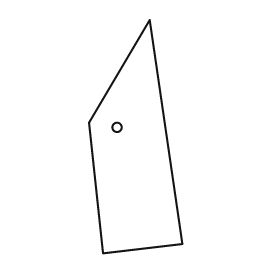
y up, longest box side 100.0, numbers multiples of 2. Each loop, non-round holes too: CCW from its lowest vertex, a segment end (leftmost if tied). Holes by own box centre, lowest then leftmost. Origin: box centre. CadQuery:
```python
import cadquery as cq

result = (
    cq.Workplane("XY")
    .moveTo(-14.0, -50.0)
    .lineTo(20.0, -46.0)
    .lineTo(6.0, 50.0)
    .lineTo(-20.0, 6.0)
    .close()
    .moveTo(-8.0, 4.0)
    .circle(2.0)
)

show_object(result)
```